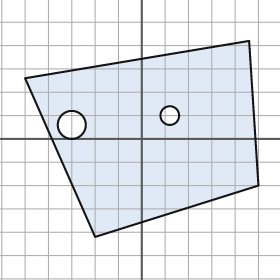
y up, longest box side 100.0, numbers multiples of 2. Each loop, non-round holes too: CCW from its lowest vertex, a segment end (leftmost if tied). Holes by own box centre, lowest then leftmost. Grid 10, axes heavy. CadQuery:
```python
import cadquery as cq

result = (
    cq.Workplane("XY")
    .moveTo(-20.0, -42.0)
    .lineTo(50.0, -20.0)
    .lineTo(46.0, 42.0)
    .lineTo(-50.0, 26.0)
    .close()
    .moveTo(-30.0, 6.0)
    .circle(6.0)
    .moveTo(12.0, 10.0)
    .circle(4.0)
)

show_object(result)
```